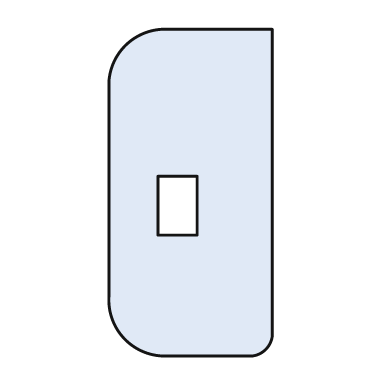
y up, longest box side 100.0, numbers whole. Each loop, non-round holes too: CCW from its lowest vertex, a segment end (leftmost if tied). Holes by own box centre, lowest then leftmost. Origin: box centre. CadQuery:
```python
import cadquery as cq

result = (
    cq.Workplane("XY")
    .moveTo(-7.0, -50.0)
    .lineTo(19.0, -50.0)
    .threePointArc((23.0, -48.0), (25.0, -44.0))
    .lineTo(25.0, 50.0)
    .lineTo(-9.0, 50.0)
    .threePointArc((-20.0, 45.0), (-25.0, 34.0))
    .lineTo(-25.0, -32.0)
    .threePointArc((-20.0, -45.0), (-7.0, -50.0))
    .close()
    .moveTo(-10.0, -13.0)
    .lineTo(2.0, -13.0)
    .lineTo(2.0, 5.0)
    .lineTo(-10.0, 5.0)
    .close()
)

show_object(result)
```